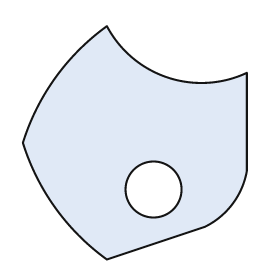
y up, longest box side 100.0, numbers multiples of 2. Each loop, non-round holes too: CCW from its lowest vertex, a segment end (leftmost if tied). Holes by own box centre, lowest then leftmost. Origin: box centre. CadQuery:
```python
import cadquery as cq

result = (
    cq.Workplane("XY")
    .moveTo(-12.0, -50.0)
    .lineTo(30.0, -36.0)
    .threePointArc((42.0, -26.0), (48.0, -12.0))
    .lineTo(48.0, 30.0)
    .threePointArc((14.0, 28.0), (-12.0, 50.0))
    .threePointArc((-34.0, 28.0), (-48.0, 0.0))
    .threePointArc((-34.0, -28.0), (-12.0, -50.0))
    .close()
    .moveTo(8.0, -20.0)
    .circle(12.0)
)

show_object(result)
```